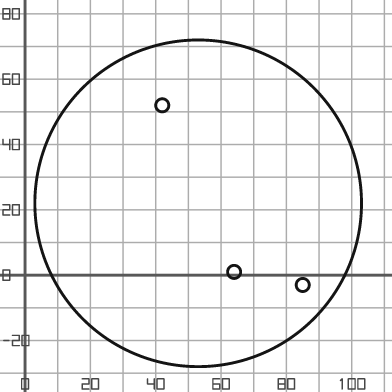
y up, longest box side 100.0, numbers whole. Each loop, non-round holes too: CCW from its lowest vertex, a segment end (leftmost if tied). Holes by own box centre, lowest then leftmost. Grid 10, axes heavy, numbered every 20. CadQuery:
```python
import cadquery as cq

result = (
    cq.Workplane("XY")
    .moveTo(53.0, 22.0)
    .circle(50.0)
    .moveTo(85.0, -3.0)
    .circle(2.0)
    .moveTo(64.0, 1.0)
    .circle(2.0)
    .moveTo(42.0, 52.0)
    .circle(2.0)
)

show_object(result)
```